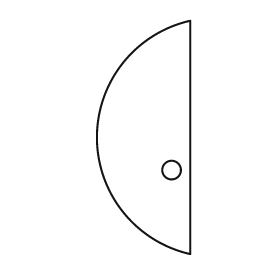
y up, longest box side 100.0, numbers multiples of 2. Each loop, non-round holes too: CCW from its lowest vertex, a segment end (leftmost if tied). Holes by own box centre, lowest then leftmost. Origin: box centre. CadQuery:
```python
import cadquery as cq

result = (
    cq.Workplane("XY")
    .moveTo(20.0, -50.0)
    .lineTo(20.0, 50.0)
    .threePointArc((-20.0, 0.0), (20.0, -50.0))
    .close()
    .moveTo(12.0, -14.0)
    .circle(4.0)
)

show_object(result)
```